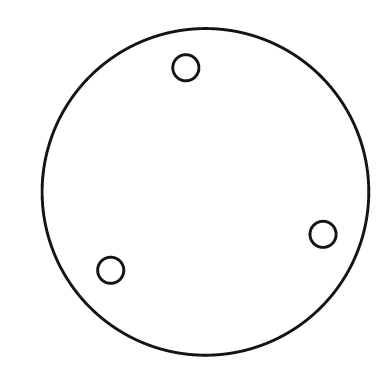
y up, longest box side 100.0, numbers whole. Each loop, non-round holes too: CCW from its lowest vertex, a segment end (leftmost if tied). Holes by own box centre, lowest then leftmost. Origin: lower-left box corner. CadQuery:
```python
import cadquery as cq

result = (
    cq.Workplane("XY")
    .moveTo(50.0, 50.0)
    .circle(50.0)
    .moveTo(21.0, 26.0)
    .circle(4.0)
    .moveTo(86.0, 37.0)
    .circle(4.0)
    .moveTo(44.0, 88.0)
    .circle(4.0)
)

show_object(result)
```